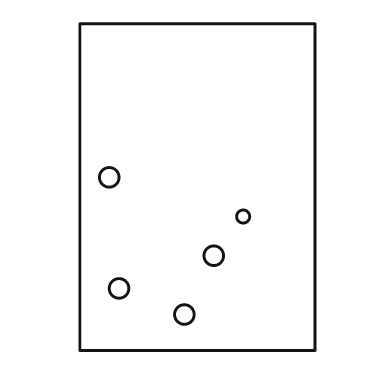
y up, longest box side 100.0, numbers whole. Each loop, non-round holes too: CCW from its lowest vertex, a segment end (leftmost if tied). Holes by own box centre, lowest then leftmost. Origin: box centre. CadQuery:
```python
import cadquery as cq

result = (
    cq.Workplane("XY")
    .moveTo(-36.0, -50.0)
    .lineTo(36.0, -50.0)
    .lineTo(36.0, 50.0)
    .lineTo(-36.0, 50.0)
    .close()
    .moveTo(-4.0, -39.0)
    .circle(3.0)
    .moveTo(-24.0, -31.0)
    .circle(3.0)
    .moveTo(5.0, -21.0)
    .circle(3.0)
    .moveTo(14.0, -9.0)
    .circle(2.0)
    .moveTo(-27.0, 3.0)
    .circle(3.0)
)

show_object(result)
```